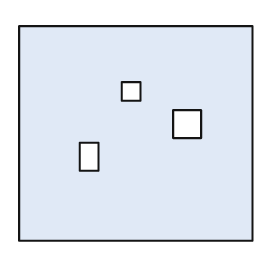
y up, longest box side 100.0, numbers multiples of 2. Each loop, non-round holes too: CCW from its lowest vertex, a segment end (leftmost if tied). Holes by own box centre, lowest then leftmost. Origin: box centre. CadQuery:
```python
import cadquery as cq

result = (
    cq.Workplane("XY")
    .moveTo(-50.0, -46.0)
    .lineTo(50.0, -46.0)
    .lineTo(50.0, 46.0)
    .lineTo(-50.0, 46.0)
    .close()
    .moveTo(-24.0, -16.0)
    .lineTo(-16.0, -16.0)
    .lineTo(-16.0, -4.0)
    .lineTo(-24.0, -4.0)
    .close()
    .moveTo(16.0, -2.0)
    .lineTo(28.0, -2.0)
    .lineTo(28.0, 10.0)
    .lineTo(16.0, 10.0)
    .close()
    .moveTo(-6.0, 14.0)
    .lineTo(2.0, 14.0)
    .lineTo(2.0, 22.0)
    .lineTo(-6.0, 22.0)
    .close()
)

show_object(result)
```